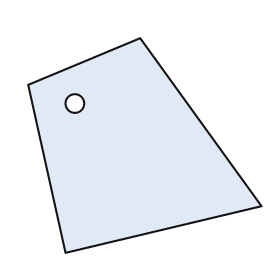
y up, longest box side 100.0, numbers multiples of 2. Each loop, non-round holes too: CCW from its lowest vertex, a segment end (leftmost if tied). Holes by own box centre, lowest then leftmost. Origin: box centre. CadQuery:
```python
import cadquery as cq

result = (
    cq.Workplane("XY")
    .moveTo(-34.0, -46.0)
    .lineTo(50.0, -26.0)
    .lineTo(-2.0, 46.0)
    .lineTo(-50.0, 26.0)
    .close()
    .moveTo(-30.0, 18.0)
    .circle(4.0)
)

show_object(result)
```